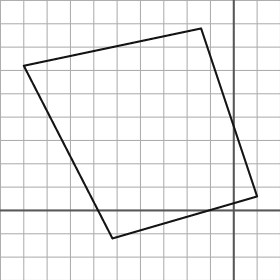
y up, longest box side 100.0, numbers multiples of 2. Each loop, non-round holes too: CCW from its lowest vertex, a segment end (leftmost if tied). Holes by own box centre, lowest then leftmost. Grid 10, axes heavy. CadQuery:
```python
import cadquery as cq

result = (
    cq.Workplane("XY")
    .moveTo(-52.0, -12.0)
    .lineTo(10.0, 6.0)
    .lineTo(-14.0, 78.0)
    .lineTo(-90.0, 62.0)
    .close()
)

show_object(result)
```